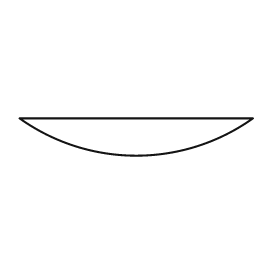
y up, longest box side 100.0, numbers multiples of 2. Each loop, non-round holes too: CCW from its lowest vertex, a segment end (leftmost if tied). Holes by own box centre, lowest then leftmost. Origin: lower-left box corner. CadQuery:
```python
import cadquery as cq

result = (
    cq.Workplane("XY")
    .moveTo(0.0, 16.0)
    .threePointArc((50.0, 0.0), (100.0, 16.0))
    .close()
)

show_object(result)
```